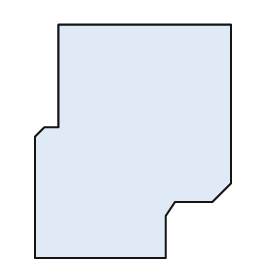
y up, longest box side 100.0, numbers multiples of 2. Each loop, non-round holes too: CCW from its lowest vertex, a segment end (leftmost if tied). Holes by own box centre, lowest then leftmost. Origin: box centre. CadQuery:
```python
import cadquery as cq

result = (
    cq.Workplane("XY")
    .moveTo(-42.0, -50.0)
    .lineTo(14.0, -50.0)
    .lineTo(14.0, -32.0)
    .lineTo(18.0, -26.0)
    .lineTo(34.0, -26.0)
    .lineTo(42.0, -18.0)
    .lineTo(42.0, 50.0)
    .lineTo(-32.0, 50.0)
    .lineTo(-32.0, 6.0)
    .lineTo(-38.0, 6.0)
    .lineTo(-42.0, 2.0)
    .close()
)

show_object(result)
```